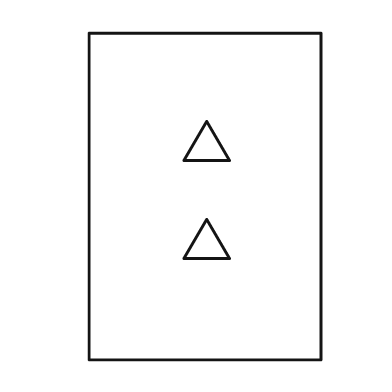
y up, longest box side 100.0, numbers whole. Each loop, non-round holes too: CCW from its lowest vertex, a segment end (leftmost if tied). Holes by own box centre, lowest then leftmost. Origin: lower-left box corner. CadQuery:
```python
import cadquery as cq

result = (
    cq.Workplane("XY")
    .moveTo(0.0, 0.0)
    .lineTo(71.0, 0.0)
    .lineTo(71.0, 100.0)
    .lineTo(0.0, 100.0)
    .close()
    .moveTo(29.0, 31.0)
    .lineTo(43.0, 31.0)
    .lineTo(36.0, 43.0)
    .close()
    .moveTo(29.0, 61.0)
    .lineTo(43.0, 61.0)
    .lineTo(36.0, 73.0)
    .close()
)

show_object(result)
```